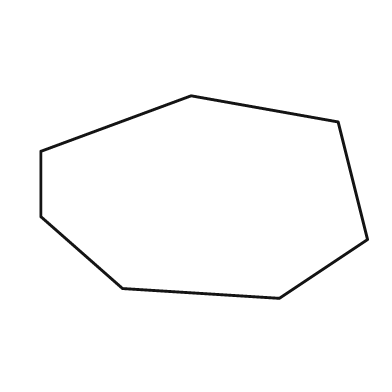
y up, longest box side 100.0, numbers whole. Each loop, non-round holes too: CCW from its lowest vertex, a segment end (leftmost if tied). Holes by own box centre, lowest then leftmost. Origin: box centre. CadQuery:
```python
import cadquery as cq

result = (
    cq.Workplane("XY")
    .moveTo(23.0, -31.0)
    .lineTo(50.0, -13.0)
    .lineTo(41.0, 23.0)
    .lineTo(-4.0, 31.0)
    .lineTo(-50.0, 14.0)
    .lineTo(-50.0, -6.0)
    .lineTo(-25.0, -28.0)
    .close()
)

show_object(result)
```